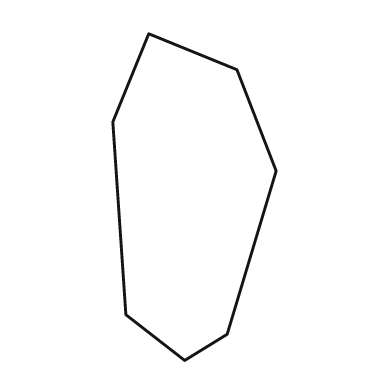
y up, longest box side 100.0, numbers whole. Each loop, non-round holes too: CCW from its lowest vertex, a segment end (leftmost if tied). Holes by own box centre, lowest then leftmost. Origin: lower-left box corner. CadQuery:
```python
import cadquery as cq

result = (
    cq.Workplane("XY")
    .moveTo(22.0, 0.0)
    .lineTo(35.0, 8.0)
    .lineTo(50.0, 58.0)
    .lineTo(38.0, 89.0)
    .lineTo(11.0, 100.0)
    .lineTo(0.0, 73.0)
    .lineTo(4.0, 14.0)
    .close()
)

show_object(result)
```